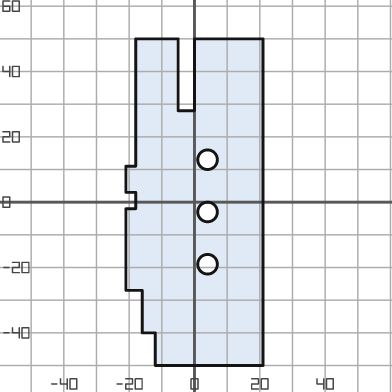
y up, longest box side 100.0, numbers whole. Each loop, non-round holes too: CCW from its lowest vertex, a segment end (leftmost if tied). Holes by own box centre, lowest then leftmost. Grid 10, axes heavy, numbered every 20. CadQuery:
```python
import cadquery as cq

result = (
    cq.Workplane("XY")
    .moveTo(-12.0, -50.0)
    .lineTo(21.0, -50.0)
    .lineTo(21.0, 50.0)
    .lineTo(0.0, 50.0)
    .lineTo(0.0, 28.0)
    .lineTo(-5.0, 28.0)
    .lineTo(-5.0, 50.0)
    .lineTo(-18.0, 50.0)
    .lineTo(-18.0, 11.0)
    .lineTo(-21.0, 11.0)
    .lineTo(-21.0, 3.0)
    .lineTo(-18.0, 3.0)
    .lineTo(-18.0, -2.0)
    .lineTo(-21.0, -2.0)
    .lineTo(-21.0, -27.0)
    .lineTo(-16.0, -27.0)
    .lineTo(-16.0, -40.0)
    .lineTo(-12.0, -40.0)
    .close()
    .moveTo(4.0, -19.0)
    .circle(3.0)
    .moveTo(4.0, -3.0)
    .circle(3.0)
    .moveTo(4.0, 13.0)
    .circle(3.0)
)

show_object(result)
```